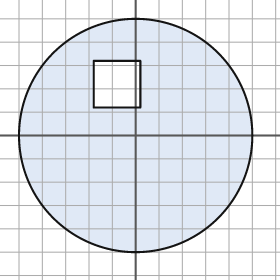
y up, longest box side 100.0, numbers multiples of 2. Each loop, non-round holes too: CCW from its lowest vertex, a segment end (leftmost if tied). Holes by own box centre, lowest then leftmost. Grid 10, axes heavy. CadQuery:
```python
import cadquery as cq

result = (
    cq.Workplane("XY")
    .moveTo(0.0, 0.0)
    .circle(50.0)
    .moveTo(-18.0, 12.0)
    .lineTo(2.0, 12.0)
    .lineTo(2.0, 32.0)
    .lineTo(-18.0, 32.0)
    .close()
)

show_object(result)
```